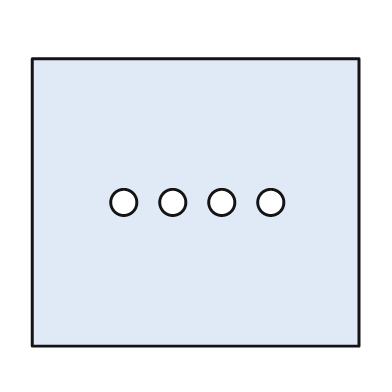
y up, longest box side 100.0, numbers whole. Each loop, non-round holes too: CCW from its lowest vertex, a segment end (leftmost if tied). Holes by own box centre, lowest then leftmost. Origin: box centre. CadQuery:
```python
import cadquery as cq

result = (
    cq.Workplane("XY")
    .moveTo(-50.0, -44.0)
    .lineTo(50.0, -44.0)
    .lineTo(50.0, 44.0)
    .lineTo(-50.0, 44.0)
    .close()
    .moveTo(-22.0, 0.0)
    .circle(4.0)
    .moveTo(-7.0, 0.0)
    .circle(4.0)
    .moveTo(8.0, 0.0)
    .circle(4.0)
    .moveTo(23.0, 0.0)
    .circle(4.0)
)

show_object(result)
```